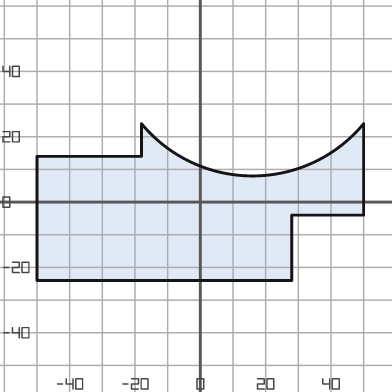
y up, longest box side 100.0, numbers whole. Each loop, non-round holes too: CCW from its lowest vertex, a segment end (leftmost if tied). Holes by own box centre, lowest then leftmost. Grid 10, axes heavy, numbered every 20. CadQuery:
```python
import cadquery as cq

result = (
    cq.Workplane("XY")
    .moveTo(-50.0, -24.0)
    .lineTo(28.0, -24.0)
    .lineTo(28.0, -4.0)
    .lineTo(50.0, -4.0)
    .lineTo(50.0, 24.0)
    .threePointArc((16.0, 8.0), (-18.0, 24.0))
    .lineTo(-18.0, 14.0)
    .lineTo(-50.0, 14.0)
    .close()
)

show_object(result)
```